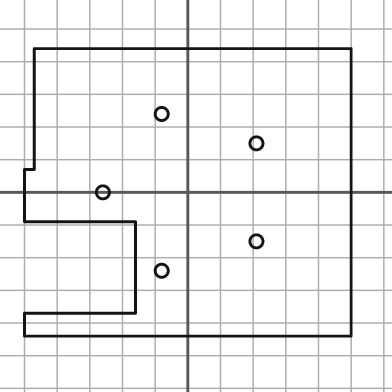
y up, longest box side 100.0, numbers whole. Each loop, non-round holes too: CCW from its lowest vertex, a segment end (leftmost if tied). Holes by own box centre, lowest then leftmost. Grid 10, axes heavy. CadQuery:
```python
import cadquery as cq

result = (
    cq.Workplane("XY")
    .moveTo(-50.0, -44.0)
    .lineTo(50.0, -44.0)
    .lineTo(50.0, 44.0)
    .lineTo(-47.0, 44.0)
    .lineTo(-47.0, 7.0)
    .lineTo(-50.0, 7.0)
    .lineTo(-50.0, -9.0)
    .lineTo(-16.0, -9.0)
    .lineTo(-16.0, -37.0)
    .lineTo(-50.0, -37.0)
    .close()
    .moveTo(-8.0, -24.0)
    .circle(2.0)
    .moveTo(21.0, -15.0)
    .circle(2.0)
    .moveTo(-26.0, 0.0)
    .circle(2.0)
    .moveTo(21.0, 15.0)
    .circle(2.0)
    .moveTo(-8.0, 24.0)
    .circle(2.0)
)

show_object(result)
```